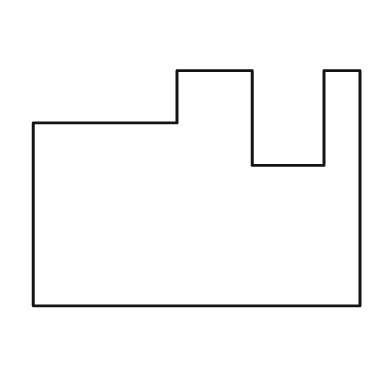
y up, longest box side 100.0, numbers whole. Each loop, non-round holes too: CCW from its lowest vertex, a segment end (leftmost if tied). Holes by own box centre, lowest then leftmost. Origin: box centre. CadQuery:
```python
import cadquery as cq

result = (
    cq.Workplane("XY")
    .moveTo(-50.0, -36.0)
    .lineTo(50.0, -36.0)
    .lineTo(50.0, 36.0)
    .lineTo(39.0, 36.0)
    .lineTo(39.0, 7.0)
    .lineTo(17.0, 7.0)
    .lineTo(17.0, 36.0)
    .lineTo(-6.0, 36.0)
    .lineTo(-6.0, 20.0)
    .lineTo(-50.0, 20.0)
    .close()
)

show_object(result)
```